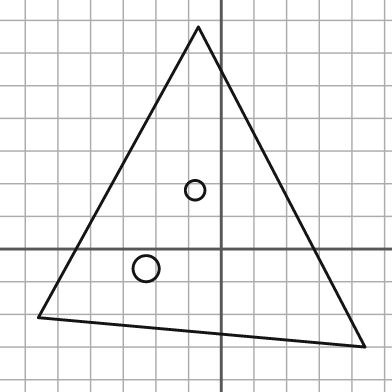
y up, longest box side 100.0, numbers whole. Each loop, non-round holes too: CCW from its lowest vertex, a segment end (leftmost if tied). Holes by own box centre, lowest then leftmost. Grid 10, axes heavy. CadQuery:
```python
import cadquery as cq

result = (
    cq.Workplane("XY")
    .moveTo(44.0, -30.0)
    .lineTo(-7.0, 68.0)
    .lineTo(-56.0, -21.0)
    .close()
    .moveTo(-23.0, -6.0)
    .circle(4.0)
    .moveTo(-8.0, 18.0)
    .circle(3.0)
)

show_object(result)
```